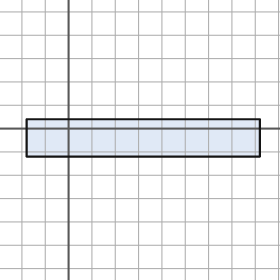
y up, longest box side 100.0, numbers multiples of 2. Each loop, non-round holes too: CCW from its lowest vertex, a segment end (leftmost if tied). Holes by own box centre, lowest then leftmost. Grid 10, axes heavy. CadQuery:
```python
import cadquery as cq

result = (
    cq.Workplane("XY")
    .moveTo(-18.0, -12.0)
    .lineTo(82.0, -12.0)
    .lineTo(82.0, 4.0)
    .lineTo(-18.0, 4.0)
    .close()
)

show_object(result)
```